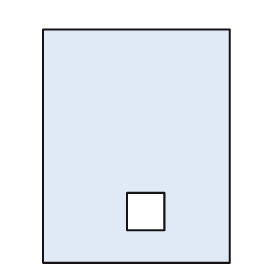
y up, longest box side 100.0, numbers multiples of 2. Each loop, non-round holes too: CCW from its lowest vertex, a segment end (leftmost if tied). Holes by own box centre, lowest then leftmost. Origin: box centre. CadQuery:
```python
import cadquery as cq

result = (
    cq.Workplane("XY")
    .moveTo(-40.0, -50.0)
    .lineTo(40.0, -50.0)
    .lineTo(40.0, 50.0)
    .lineTo(-40.0, 50.0)
    .close()
    .moveTo(-4.0, -36.0)
    .lineTo(12.0, -36.0)
    .lineTo(12.0, -20.0)
    .lineTo(-4.0, -20.0)
    .close()
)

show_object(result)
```